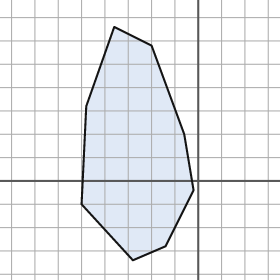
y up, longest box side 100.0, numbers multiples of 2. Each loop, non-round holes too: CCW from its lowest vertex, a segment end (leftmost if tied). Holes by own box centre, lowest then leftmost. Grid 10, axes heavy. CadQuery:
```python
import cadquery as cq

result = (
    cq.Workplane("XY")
    .moveTo(-28.0, -34.0)
    .lineTo(-14.0, -28.0)
    .lineTo(-2.0, -4.0)
    .lineTo(-6.0, 20.0)
    .lineTo(-20.0, 58.0)
    .lineTo(-36.0, 66.0)
    .lineTo(-48.0, 32.0)
    .lineTo(-50.0, -10.0)
    .close()
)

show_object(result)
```